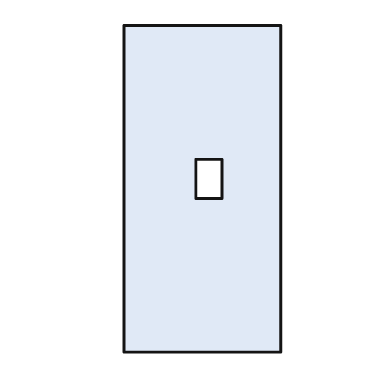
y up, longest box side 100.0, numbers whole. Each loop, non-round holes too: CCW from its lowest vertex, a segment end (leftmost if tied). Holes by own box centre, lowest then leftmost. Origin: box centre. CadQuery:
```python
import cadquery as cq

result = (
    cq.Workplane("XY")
    .moveTo(-24.0, -50.0)
    .lineTo(24.0, -50.0)
    .lineTo(24.0, 50.0)
    .lineTo(-24.0, 50.0)
    .close()
    .moveTo(-2.0, -3.0)
    .lineTo(6.0, -3.0)
    .lineTo(6.0, 9.0)
    .lineTo(-2.0, 9.0)
    .close()
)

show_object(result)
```